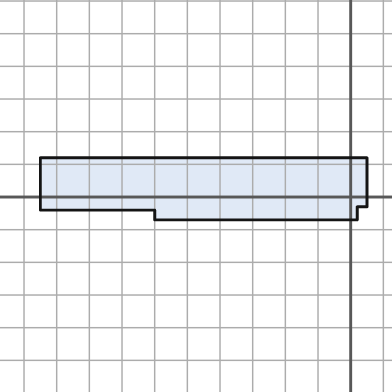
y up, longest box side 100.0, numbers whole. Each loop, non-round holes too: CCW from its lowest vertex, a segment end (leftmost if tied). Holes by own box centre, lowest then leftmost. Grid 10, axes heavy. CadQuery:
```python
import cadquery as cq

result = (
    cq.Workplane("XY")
    .moveTo(-60.0, -7.0)
    .lineTo(2.0, -7.0)
    .lineTo(2.0, -3.0)
    .lineTo(5.0, -3.0)
    .lineTo(5.0, 12.0)
    .lineTo(-95.0, 12.0)
    .lineTo(-95.0, -4.0)
    .lineTo(-60.0, -4.0)
    .close()
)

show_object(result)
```